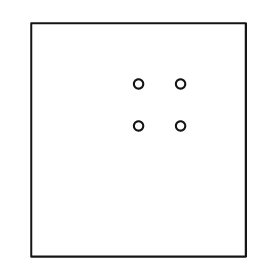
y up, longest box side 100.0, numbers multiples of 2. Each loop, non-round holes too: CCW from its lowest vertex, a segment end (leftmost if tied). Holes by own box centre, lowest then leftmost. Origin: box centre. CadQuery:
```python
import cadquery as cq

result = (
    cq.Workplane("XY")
    .moveTo(-46.0, -50.0)
    .lineTo(46.0, -50.0)
    .lineTo(46.0, 50.0)
    .lineTo(-46.0, 50.0)
    .close()
    .moveTo(0.0, 6.0)
    .circle(2.0)
    .moveTo(18.0, 6.0)
    .circle(2.0)
    .moveTo(0.0, 24.0)
    .circle(2.0)
    .moveTo(18.0, 24.0)
    .circle(2.0)
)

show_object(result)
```